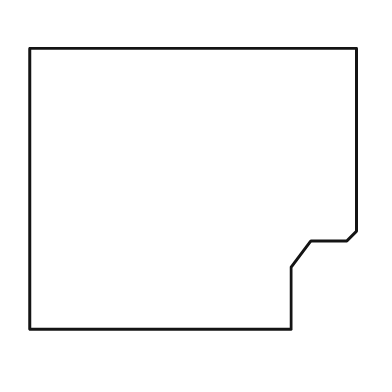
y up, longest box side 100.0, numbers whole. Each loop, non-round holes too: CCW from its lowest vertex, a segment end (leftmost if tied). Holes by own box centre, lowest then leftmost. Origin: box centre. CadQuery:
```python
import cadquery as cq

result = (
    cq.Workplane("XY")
    .moveTo(-50.0, -43.0)
    .lineTo(30.0, -43.0)
    .lineTo(30.0, -24.0)
    .lineTo(36.0, -16.0)
    .lineTo(47.0, -16.0)
    .lineTo(50.0, -13.0)
    .lineTo(50.0, 43.0)
    .lineTo(-50.0, 43.0)
    .close()
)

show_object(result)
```